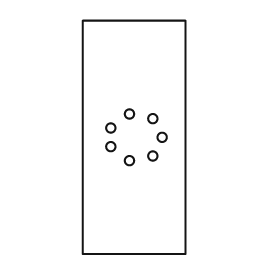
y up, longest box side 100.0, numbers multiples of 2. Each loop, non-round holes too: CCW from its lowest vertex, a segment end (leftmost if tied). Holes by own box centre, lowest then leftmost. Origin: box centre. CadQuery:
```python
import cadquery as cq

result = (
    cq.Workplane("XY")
    .moveTo(-22.0, -50.0)
    .lineTo(22.0, -50.0)
    .lineTo(22.0, 50.0)
    .lineTo(-22.0, 50.0)
    .close()
    .moveTo(-2.0, -10.0)
    .circle(2.0)
    .moveTo(8.0, -8.0)
    .circle(2.0)
    .moveTo(-10.0, -4.0)
    .circle(2.0)
    .moveTo(12.0, 0.0)
    .circle(2.0)
    .moveTo(-10.0, 4.0)
    .circle(2.0)
    .moveTo(8.0, 8.0)
    .circle(2.0)
    .moveTo(-2.0, 10.0)
    .circle(2.0)
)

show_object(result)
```